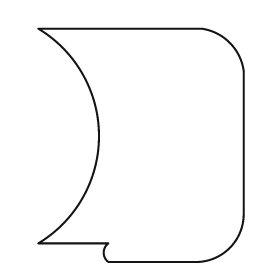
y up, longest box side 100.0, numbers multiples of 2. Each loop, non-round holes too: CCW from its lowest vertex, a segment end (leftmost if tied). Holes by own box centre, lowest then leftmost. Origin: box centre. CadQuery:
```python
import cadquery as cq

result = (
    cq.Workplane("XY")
    .moveTo(-14.0, -50.0)
    .lineTo(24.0, -50.0)
    .threePointArc((38.0, -44.0), (44.0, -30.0))
    .lineTo(44.0, 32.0)
    .threePointArc((38.0, 44.0), (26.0, 50.0))
    .lineTo(-44.0, 50.0)
    .threePointArc((-18.0, 4.0), (-44.0, -42.0))
    .lineTo(-14.0, -42.0)
    .threePointArc((-16.0, -46.0), (-14.0, -50.0))
    .close()
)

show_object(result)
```